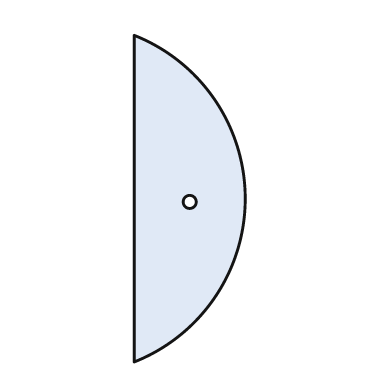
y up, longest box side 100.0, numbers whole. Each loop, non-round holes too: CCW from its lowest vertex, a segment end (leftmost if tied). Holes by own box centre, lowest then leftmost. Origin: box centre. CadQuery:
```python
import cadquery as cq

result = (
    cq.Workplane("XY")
    .moveTo(-17.0, -50.0)
    .threePointArc((17.0, 0.0), (-17.0, 50.0))
    .close()
    .moveTo(0.0, -1.0)
    .circle(2.0)
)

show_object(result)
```